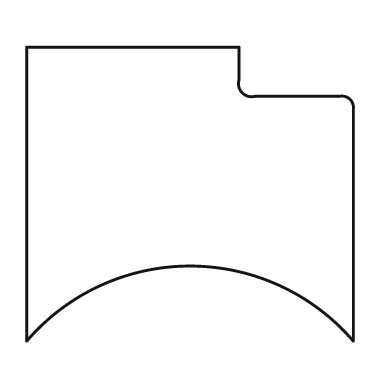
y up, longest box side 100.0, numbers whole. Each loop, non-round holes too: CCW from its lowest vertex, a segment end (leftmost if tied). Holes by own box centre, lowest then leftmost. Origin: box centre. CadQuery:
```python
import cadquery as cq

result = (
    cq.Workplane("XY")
    .moveTo(-50.0, -45.0)
    .threePointArc((0.0, -22.0), (50.0, -45.0))
    .lineTo(50.0, 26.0)
    .threePointArc((49.0, 29.0), (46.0, 30.0))
    .lineTo(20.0, 30.0)
    .threePointArc((16.0, 31.0), (15.0, 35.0))
    .lineTo(15.0, 45.0)
    .lineTo(-50.0, 45.0)
    .close()
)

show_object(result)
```